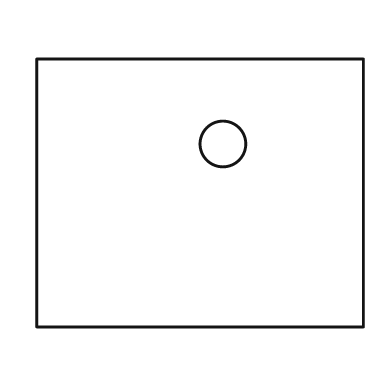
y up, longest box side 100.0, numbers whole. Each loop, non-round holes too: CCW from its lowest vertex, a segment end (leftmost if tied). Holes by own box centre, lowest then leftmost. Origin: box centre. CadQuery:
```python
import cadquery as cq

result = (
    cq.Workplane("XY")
    .moveTo(-50.0, -41.0)
    .lineTo(50.0, -41.0)
    .lineTo(50.0, 41.0)
    .lineTo(-50.0, 41.0)
    .close()
    .moveTo(7.0, 15.0)
    .circle(7.0)
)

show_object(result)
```